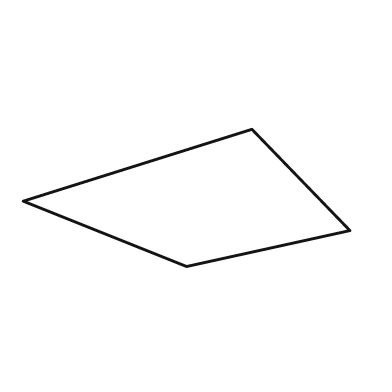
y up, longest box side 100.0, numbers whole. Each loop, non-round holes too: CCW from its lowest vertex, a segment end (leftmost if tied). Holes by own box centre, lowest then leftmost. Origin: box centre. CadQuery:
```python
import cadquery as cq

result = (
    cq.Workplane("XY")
    .moveTo(0.0, -21.0)
    .lineTo(50.0, -10.0)
    .lineTo(20.0, 21.0)
    .lineTo(-50.0, -1.0)
    .close()
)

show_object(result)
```